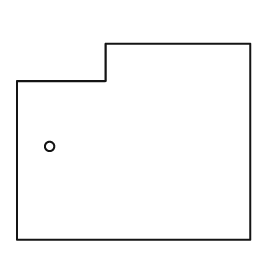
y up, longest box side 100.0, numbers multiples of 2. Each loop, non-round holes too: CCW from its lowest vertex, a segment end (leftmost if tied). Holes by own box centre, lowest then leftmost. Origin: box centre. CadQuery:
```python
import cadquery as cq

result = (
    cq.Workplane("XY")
    .moveTo(-50.0, -42.0)
    .lineTo(50.0, -42.0)
    .lineTo(50.0, 42.0)
    .lineTo(-12.0, 42.0)
    .lineTo(-12.0, 26.0)
    .lineTo(-50.0, 26.0)
    .close()
    .moveTo(-36.0, -2.0)
    .circle(2.0)
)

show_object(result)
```